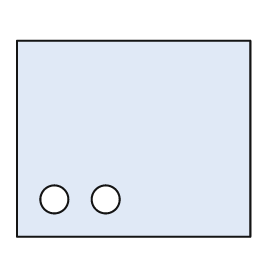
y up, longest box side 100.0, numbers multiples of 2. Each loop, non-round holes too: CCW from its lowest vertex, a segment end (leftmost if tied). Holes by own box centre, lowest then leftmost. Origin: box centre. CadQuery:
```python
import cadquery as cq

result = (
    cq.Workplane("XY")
    .moveTo(-50.0, -42.0)
    .lineTo(50.0, -42.0)
    .lineTo(50.0, 42.0)
    .lineTo(-50.0, 42.0)
    .close()
    .moveTo(-34.0, -26.0)
    .circle(6.0)
    .moveTo(-12.0, -26.0)
    .circle(6.0)
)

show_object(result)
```